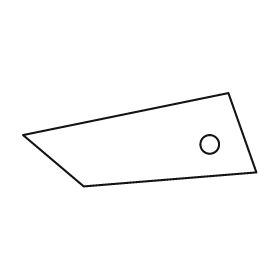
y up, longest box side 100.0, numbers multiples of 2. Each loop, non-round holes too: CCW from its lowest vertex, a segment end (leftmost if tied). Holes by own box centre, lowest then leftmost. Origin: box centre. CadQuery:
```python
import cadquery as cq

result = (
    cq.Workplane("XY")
    .moveTo(-24.0, -20.0)
    .lineTo(50.0, -14.0)
    .lineTo(38.0, 20.0)
    .lineTo(-50.0, 2.0)
    .close()
    .moveTo(30.0, -2.0)
    .circle(4.0)
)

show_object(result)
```